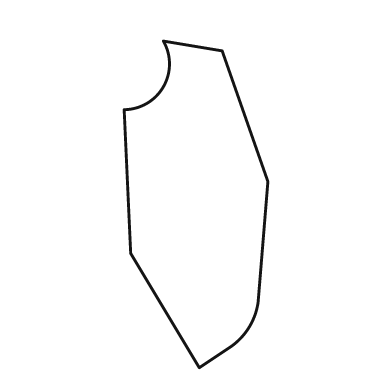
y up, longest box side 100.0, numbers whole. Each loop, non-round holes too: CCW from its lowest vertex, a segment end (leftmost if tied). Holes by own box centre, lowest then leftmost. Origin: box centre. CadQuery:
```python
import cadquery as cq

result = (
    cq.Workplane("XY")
    .moveTo(1.0, -50.0)
    .lineTo(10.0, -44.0)
    .threePointArc((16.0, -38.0), (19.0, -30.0))
    .lineTo(22.0, 7.0)
    .lineTo(8.0, 47.0)
    .lineTo(-10.0, 50.0)
    .threePointArc((-10.0, 36.0), (-22.0, 29.0))
    .lineTo(-20.0, -15.0)
    .close()
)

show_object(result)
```